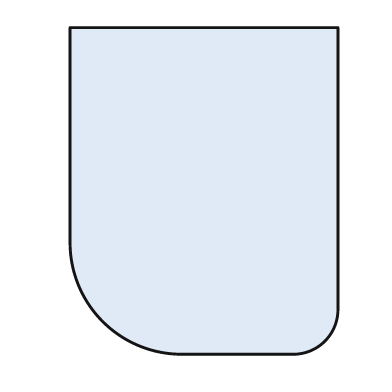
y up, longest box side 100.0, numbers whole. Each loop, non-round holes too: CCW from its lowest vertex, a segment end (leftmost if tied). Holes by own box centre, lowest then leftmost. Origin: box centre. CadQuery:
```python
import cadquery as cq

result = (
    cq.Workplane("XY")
    .moveTo(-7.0, -50.0)
    .lineTo(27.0, -50.0)
    .threePointArc((37.0, -46.0), (41.0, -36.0))
    .lineTo(41.0, 50.0)
    .lineTo(-41.0, 50.0)
    .lineTo(-41.0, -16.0)
    .threePointArc((-31.0, -40.0), (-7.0, -50.0))
    .close()
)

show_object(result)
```